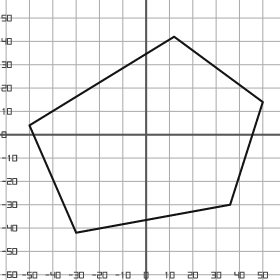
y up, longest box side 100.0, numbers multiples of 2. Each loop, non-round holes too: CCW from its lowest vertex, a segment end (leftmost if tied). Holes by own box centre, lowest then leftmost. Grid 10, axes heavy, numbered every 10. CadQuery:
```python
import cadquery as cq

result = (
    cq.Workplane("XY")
    .moveTo(-30.0, -42.0)
    .lineTo(36.0, -30.0)
    .lineTo(50.0, 14.0)
    .lineTo(12.0, 42.0)
    .lineTo(-50.0, 4.0)
    .close()
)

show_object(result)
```